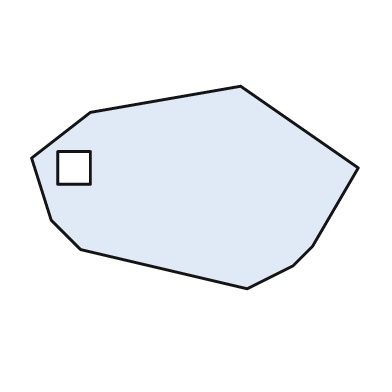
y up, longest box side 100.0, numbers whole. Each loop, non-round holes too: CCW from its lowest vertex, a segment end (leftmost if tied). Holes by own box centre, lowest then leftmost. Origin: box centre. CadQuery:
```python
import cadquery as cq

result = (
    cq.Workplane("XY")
    .moveTo(16.0, -31.0)
    .lineTo(30.0, -24.0)
    .lineTo(36.0, -18.0)
    .lineTo(50.0, 6.0)
    .lineTo(14.0, 31.0)
    .lineTo(-32.0, 23.0)
    .lineTo(-50.0, 9.0)
    .lineTo(-44.0, -10.0)
    .lineTo(-35.0, -19.0)
    .close()
    .moveTo(-42.0, 1.0)
    .lineTo(-32.0, 1.0)
    .lineTo(-32.0, 11.0)
    .lineTo(-42.0, 11.0)
    .close()
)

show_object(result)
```